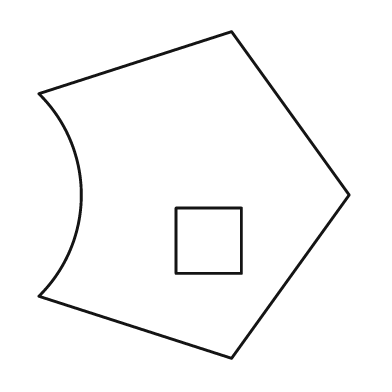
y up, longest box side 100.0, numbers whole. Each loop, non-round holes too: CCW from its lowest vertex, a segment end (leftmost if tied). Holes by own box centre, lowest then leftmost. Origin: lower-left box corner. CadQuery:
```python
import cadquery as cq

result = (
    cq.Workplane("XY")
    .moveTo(59.0, 0.0)
    .lineTo(95.0, 50.0)
    .lineTo(59.0, 100.0)
    .lineTo(0.0, 81.0)
    .threePointArc((13.0, 50.0), (0.0, 19.0))
    .close()
    .moveTo(42.0, 26.0)
    .lineTo(62.0, 26.0)
    .lineTo(62.0, 46.0)
    .lineTo(42.0, 46.0)
    .close()
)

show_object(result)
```